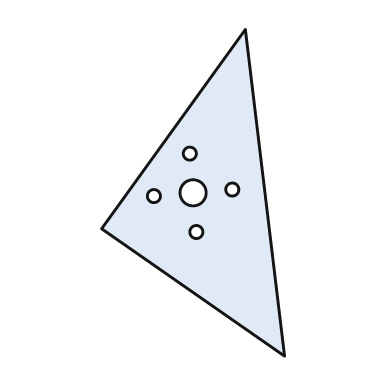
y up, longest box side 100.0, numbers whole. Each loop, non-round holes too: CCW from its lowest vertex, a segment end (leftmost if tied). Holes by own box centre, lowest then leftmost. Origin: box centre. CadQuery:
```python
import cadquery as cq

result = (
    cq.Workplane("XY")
    .moveTo(28.0, -50.0)
    .lineTo(16.0, 50.0)
    .lineTo(-28.0, -11.0)
    .close()
    .moveTo(1.0, -12.0)
    .circle(2.0)
    .moveTo(-12.0, -1.0)
    .circle(2.0)
    .moveTo(0.0, 0.0)
    .circle(4.0)
    .moveTo(12.0, 1.0)
    .circle(2.0)
    .moveTo(-1.0, 12.0)
    .circle(2.0)
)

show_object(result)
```